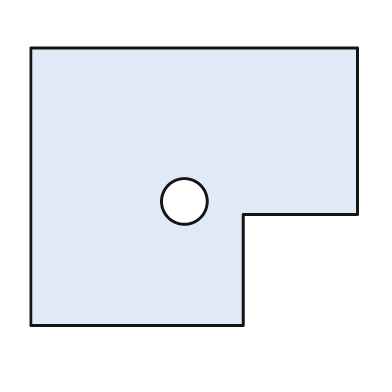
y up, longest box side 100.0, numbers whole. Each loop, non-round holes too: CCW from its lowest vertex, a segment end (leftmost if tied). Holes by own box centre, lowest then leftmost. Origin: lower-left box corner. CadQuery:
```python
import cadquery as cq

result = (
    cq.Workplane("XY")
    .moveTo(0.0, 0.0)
    .lineTo(65.0, 0.0)
    .lineTo(65.0, 34.0)
    .lineTo(100.0, 34.0)
    .lineTo(100.0, 85.0)
    .lineTo(0.0, 85.0)
    .close()
    .moveTo(47.0, 38.0)
    .circle(7.0)
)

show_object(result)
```